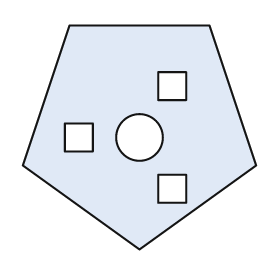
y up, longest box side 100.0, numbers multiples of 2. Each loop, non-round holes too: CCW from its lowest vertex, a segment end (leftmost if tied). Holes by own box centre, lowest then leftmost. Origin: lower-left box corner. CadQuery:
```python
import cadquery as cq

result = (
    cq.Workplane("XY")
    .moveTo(50.0, 0.0)
    .lineTo(100.0, 36.0)
    .lineTo(80.0, 96.0)
    .lineTo(20.0, 96.0)
    .lineTo(0.0, 36.0)
    .close()
    .moveTo(58.0, 20.0)
    .lineTo(70.0, 20.0)
    .lineTo(70.0, 32.0)
    .lineTo(58.0, 32.0)
    .close()
    .moveTo(18.0, 42.0)
    .lineTo(30.0, 42.0)
    .lineTo(30.0, 54.0)
    .lineTo(18.0, 54.0)
    .close()
    .moveTo(50.0, 48.0)
    .circle(10.0)
    .moveTo(58.0, 64.0)
    .lineTo(70.0, 64.0)
    .lineTo(70.0, 76.0)
    .lineTo(58.0, 76.0)
    .close()
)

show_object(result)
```